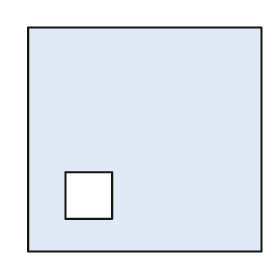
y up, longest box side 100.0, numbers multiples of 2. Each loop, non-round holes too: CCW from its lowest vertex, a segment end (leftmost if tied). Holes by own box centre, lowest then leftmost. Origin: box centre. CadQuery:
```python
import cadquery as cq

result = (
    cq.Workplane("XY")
    .moveTo(-50.0, -48.0)
    .lineTo(50.0, -48.0)
    .lineTo(50.0, 48.0)
    .lineTo(-50.0, 48.0)
    .close()
    .moveTo(-34.0, -34.0)
    .lineTo(-14.0, -34.0)
    .lineTo(-14.0, -14.0)
    .lineTo(-34.0, -14.0)
    .close()
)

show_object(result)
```